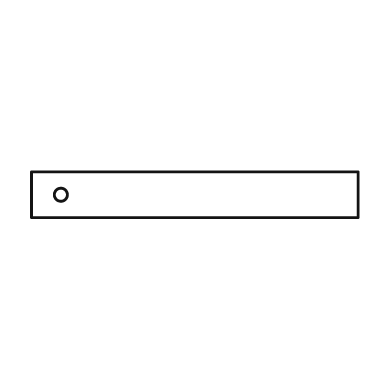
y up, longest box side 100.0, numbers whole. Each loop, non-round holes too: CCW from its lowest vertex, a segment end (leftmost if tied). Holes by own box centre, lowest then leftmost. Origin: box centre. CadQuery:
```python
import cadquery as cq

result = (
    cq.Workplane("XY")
    .moveTo(-50.0, -7.0)
    .lineTo(50.0, -7.0)
    .lineTo(50.0, 7.0)
    .lineTo(-50.0, 7.0)
    .close()
    .moveTo(-41.0, 0.0)
    .circle(2.0)
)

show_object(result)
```